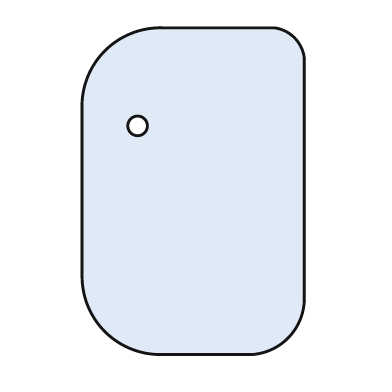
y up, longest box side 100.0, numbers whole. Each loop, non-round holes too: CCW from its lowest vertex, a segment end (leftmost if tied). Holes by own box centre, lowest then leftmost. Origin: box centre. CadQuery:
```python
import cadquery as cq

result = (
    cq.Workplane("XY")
    .moveTo(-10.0, -50.0)
    .lineTo(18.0, -50.0)
    .threePointArc((29.0, -45.0), (34.0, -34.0))
    .lineTo(34.0, 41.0)
    .threePointArc((31.0, 47.0), (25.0, 50.0))
    .lineTo(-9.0, 50.0)
    .threePointArc((-27.0, 43.0), (-34.0, 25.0))
    .lineTo(-34.0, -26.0)
    .threePointArc((-27.0, -43.0), (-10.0, -50.0))
    .close()
    .moveTo(-17.0, 20.0)
    .circle(3.0)
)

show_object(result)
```